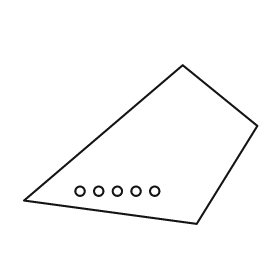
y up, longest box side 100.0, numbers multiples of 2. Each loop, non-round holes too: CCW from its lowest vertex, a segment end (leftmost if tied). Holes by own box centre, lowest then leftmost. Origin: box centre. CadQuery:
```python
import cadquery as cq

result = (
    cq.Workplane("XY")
    .moveTo(24.0, -34.0)
    .lineTo(50.0, 8.0)
    .lineTo(18.0, 34.0)
    .lineTo(-50.0, -24.0)
    .close()
    .moveTo(-26.0, -20.0)
    .circle(2.0)
    .moveTo(-18.0, -20.0)
    .circle(2.0)
    .moveTo(-10.0, -20.0)
    .circle(2.0)
    .moveTo(-2.0, -20.0)
    .circle(2.0)
    .moveTo(6.0, -20.0)
    .circle(2.0)
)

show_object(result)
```